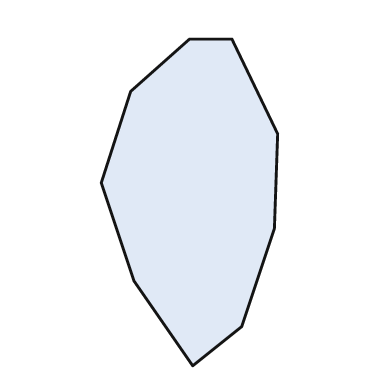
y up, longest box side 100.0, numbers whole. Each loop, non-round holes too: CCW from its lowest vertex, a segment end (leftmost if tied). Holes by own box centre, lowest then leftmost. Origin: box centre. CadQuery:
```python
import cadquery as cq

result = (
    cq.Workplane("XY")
    .moveTo(1.0, -50.0)
    .lineTo(16.0, -38.0)
    .lineTo(26.0, -8.0)
    .lineTo(27.0, 21.0)
    .lineTo(13.0, 50.0)
    .lineTo(0.0, 50.0)
    .lineTo(-18.0, 34.0)
    .lineTo(-27.0, 6.0)
    .lineTo(-17.0, -24.0)
    .close()
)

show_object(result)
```